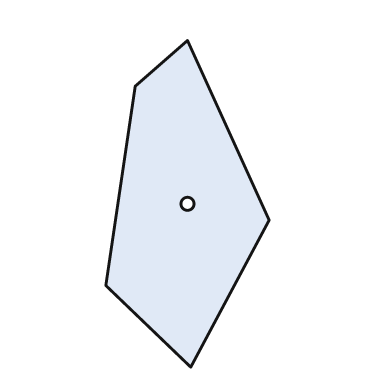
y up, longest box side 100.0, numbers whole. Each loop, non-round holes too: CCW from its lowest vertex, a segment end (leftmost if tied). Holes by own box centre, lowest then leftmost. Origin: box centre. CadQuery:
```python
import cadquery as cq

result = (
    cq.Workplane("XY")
    .moveTo(1.0, -50.0)
    .lineTo(25.0, -5.0)
    .lineTo(0.0, 50.0)
    .lineTo(-16.0, 36.0)
    .lineTo(-25.0, -25.0)
    .close()
    .moveTo(0.0, 0.0)
    .circle(2.0)
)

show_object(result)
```